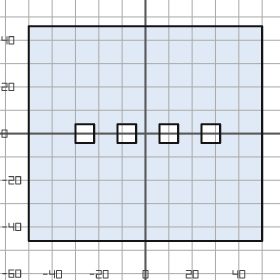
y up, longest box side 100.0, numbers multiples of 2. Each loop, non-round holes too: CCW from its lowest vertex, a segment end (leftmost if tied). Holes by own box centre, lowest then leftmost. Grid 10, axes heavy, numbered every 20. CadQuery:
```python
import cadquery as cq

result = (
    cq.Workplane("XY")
    .moveTo(-50.0, -46.0)
    .lineTo(50.0, -46.0)
    .lineTo(50.0, 46.0)
    .lineTo(-50.0, 46.0)
    .close()
    .moveTo(-30.0, -4.0)
    .lineTo(-22.0, -4.0)
    .lineTo(-22.0, 4.0)
    .lineTo(-30.0, 4.0)
    .close()
    .moveTo(-12.0, -4.0)
    .lineTo(-4.0, -4.0)
    .lineTo(-4.0, 4.0)
    .lineTo(-12.0, 4.0)
    .close()
    .moveTo(6.0, -4.0)
    .lineTo(14.0, -4.0)
    .lineTo(14.0, 4.0)
    .lineTo(6.0, 4.0)
    .close()
    .moveTo(24.0, -4.0)
    .lineTo(32.0, -4.0)
    .lineTo(32.0, 4.0)
    .lineTo(24.0, 4.0)
    .close()
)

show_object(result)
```